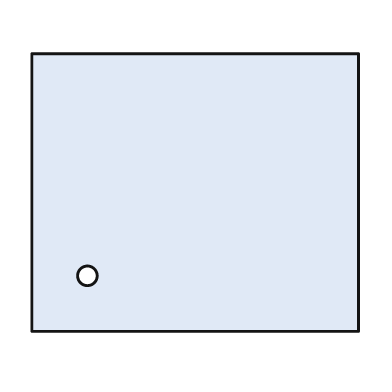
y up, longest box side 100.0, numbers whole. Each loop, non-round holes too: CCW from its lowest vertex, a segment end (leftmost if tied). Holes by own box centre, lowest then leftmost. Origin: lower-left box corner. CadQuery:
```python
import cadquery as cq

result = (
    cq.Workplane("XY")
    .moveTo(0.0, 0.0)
    .lineTo(100.0, 0.0)
    .lineTo(100.0, 85.0)
    .lineTo(0.0, 85.0)
    .close()
    .moveTo(17.0, 17.0)
    .circle(3.0)
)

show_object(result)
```